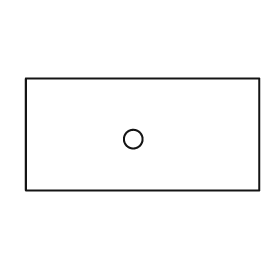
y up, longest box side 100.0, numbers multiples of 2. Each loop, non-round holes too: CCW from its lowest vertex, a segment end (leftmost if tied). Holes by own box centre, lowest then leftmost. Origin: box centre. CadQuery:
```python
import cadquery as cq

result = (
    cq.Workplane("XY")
    .moveTo(-50.0, -24.0)
    .lineTo(50.0, -24.0)
    .lineTo(50.0, 24.0)
    .lineTo(-50.0, 24.0)
    .close()
    .moveTo(-4.0, -2.0)
    .circle(4.0)
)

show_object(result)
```